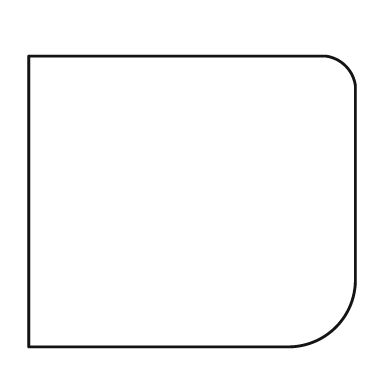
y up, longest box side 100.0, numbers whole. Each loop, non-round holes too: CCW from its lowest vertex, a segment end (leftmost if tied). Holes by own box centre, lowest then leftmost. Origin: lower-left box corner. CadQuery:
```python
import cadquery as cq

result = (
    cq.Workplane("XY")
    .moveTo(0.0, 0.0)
    .lineTo(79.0, 0.0)
    .threePointArc((94.0, 6.0), (100.0, 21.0))
    .lineTo(100.0, 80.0)
    .threePointArc((97.0, 86.0), (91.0, 89.0))
    .lineTo(0.0, 89.0)
    .close()
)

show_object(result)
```